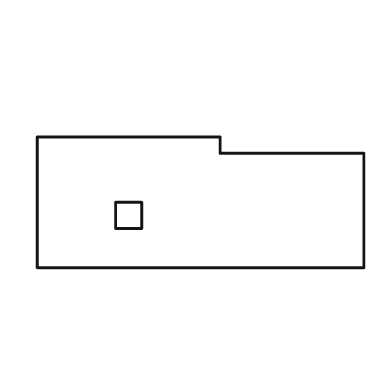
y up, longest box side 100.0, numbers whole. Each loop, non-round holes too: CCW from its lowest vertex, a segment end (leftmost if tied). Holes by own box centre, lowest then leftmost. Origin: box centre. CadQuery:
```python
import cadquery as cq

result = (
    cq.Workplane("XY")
    .moveTo(-50.0, -20.0)
    .lineTo(50.0, -20.0)
    .lineTo(50.0, 15.0)
    .lineTo(6.0, 15.0)
    .lineTo(6.0, 20.0)
    .lineTo(-50.0, 20.0)
    .close()
    .moveTo(-26.0, -8.0)
    .lineTo(-18.0, -8.0)
    .lineTo(-18.0, 0.0)
    .lineTo(-26.0, 0.0)
    .close()
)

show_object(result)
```